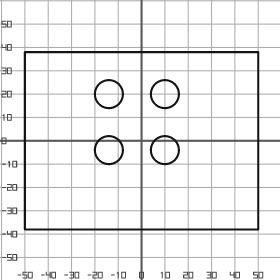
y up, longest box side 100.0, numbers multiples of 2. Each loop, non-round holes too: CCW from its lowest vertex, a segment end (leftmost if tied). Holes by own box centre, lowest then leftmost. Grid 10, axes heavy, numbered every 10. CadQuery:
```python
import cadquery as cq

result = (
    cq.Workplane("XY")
    .moveTo(-50.0, -38.0)
    .lineTo(50.0, -38.0)
    .lineTo(50.0, 38.0)
    .lineTo(-50.0, 38.0)
    .close()
    .moveTo(-14.0, -4.0)
    .circle(6.0)
    .moveTo(10.0, -4.0)
    .circle(6.0)
    .moveTo(-14.0, 20.0)
    .circle(6.0)
    .moveTo(10.0, 20.0)
    .circle(6.0)
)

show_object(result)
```